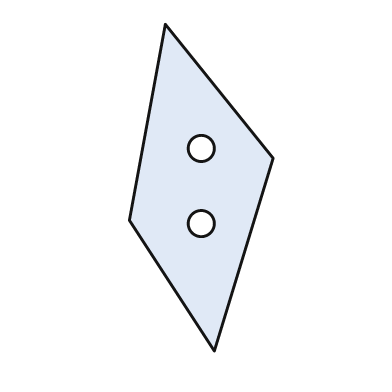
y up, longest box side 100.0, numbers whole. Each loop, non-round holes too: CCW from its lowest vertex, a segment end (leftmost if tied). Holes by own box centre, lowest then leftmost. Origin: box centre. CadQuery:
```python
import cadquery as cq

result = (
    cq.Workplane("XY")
    .moveTo(4.0, -50.0)
    .lineTo(22.0, 9.0)
    .lineTo(-11.0, 50.0)
    .lineTo(-22.0, -10.0)
    .close()
    .moveTo(0.0, -11.0)
    .circle(4.0)
    .moveTo(0.0, 12.0)
    .circle(4.0)
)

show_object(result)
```